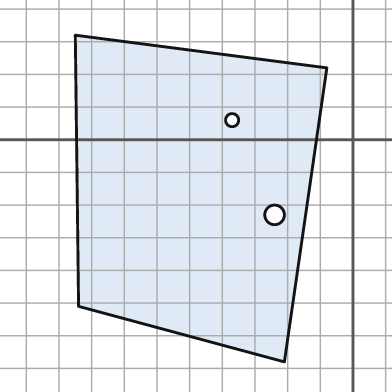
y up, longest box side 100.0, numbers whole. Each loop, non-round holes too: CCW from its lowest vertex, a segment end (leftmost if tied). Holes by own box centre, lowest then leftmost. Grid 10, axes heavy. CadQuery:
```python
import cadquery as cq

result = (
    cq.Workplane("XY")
    .moveTo(-21.0, -68.0)
    .lineTo(-8.0, 22.0)
    .lineTo(-85.0, 32.0)
    .lineTo(-84.0, -51.0)
    .close()
    .moveTo(-24.0, -23.0)
    .circle(3.0)
    .moveTo(-37.0, 6.0)
    .circle(2.0)
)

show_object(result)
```